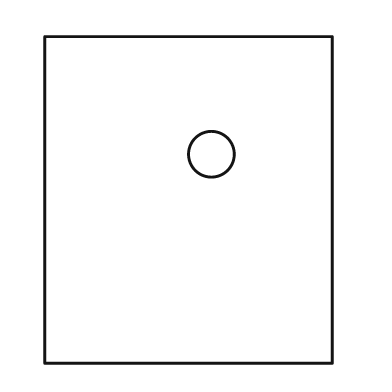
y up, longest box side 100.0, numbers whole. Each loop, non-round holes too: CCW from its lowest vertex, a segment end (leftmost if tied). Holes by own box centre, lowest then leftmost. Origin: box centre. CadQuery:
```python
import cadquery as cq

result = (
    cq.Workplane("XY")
    .moveTo(-44.0, -50.0)
    .lineTo(44.0, -50.0)
    .lineTo(44.0, 50.0)
    .lineTo(-44.0, 50.0)
    .close()
    .moveTo(7.0, 14.0)
    .circle(7.0)
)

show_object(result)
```